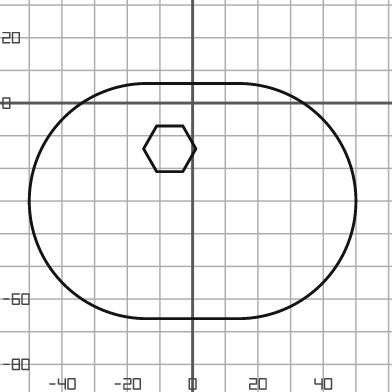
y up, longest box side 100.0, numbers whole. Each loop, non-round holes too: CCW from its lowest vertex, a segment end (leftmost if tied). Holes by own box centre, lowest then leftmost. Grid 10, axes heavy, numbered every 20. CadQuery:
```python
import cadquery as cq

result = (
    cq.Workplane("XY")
    .moveTo(-14.0, -66.0)
    .lineTo(14.0, -66.0)
    .threePointArc((50.0, -30.0), (14.0, 6.0))
    .lineTo(-14.0, 6.0)
    .threePointArc((-50.0, -30.0), (-14.0, -66.0))
    .close()
    .moveTo(-11.0, -21.0)
    .lineTo(-3.0, -21.0)
    .lineTo(1.0, -14.0)
    .lineTo(-3.0, -7.0)
    .lineTo(-11.0, -7.0)
    .lineTo(-15.0, -14.0)
    .close()
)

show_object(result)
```